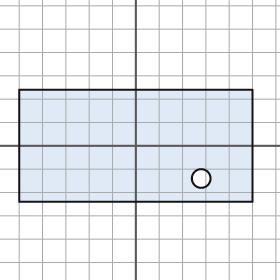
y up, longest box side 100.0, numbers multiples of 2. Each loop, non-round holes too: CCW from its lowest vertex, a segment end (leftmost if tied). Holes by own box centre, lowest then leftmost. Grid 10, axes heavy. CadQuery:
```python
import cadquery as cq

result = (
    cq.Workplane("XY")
    .moveTo(-50.0, -24.0)
    .lineTo(50.0, -24.0)
    .lineTo(50.0, 24.0)
    .lineTo(-50.0, 24.0)
    .close()
    .moveTo(28.0, -14.0)
    .circle(4.0)
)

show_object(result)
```